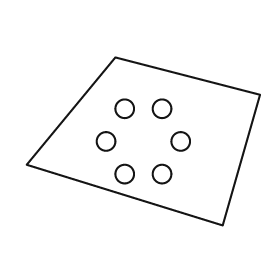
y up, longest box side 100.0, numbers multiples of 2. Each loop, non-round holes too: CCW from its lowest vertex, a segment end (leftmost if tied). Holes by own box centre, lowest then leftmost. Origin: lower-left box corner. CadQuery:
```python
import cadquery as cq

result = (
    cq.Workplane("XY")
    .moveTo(84.0, 0.0)
    .lineTo(100.0, 56.0)
    .lineTo(38.0, 72.0)
    .lineTo(0.0, 26.0)
    .close()
    .moveTo(42.0, 22.0)
    .circle(4.0)
    .moveTo(58.0, 22.0)
    .circle(4.0)
    .moveTo(34.0, 36.0)
    .circle(4.0)
    .moveTo(66.0, 36.0)
    .circle(4.0)
    .moveTo(42.0, 50.0)
    .circle(4.0)
    .moveTo(58.0, 50.0)
    .circle(4.0)
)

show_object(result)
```